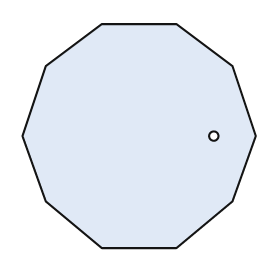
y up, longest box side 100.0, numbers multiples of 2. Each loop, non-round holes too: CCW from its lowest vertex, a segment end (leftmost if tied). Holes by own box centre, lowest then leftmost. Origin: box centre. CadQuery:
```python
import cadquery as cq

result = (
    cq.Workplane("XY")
    .moveTo(-16.0, -48.0)
    .lineTo(16.0, -48.0)
    .lineTo(40.0, -28.0)
    .lineTo(50.0, 0.0)
    .lineTo(40.0, 30.0)
    .lineTo(16.0, 48.0)
    .lineTo(-16.0, 48.0)
    .lineTo(-40.0, 30.0)
    .lineTo(-50.0, 0.0)
    .lineTo(-40.0, -28.0)
    .close()
    .moveTo(32.0, 0.0)
    .circle(2.0)
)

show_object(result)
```